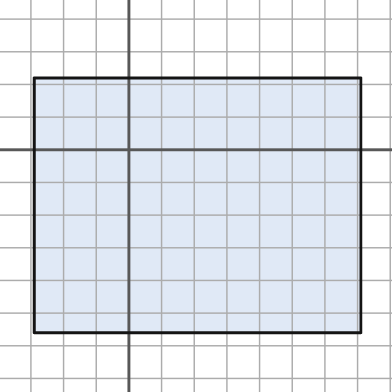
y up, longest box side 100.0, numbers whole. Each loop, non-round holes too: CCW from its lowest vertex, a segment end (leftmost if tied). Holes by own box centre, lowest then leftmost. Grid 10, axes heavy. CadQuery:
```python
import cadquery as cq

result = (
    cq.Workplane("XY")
    .moveTo(-29.0, -56.0)
    .lineTo(71.0, -56.0)
    .lineTo(71.0, 22.0)
    .lineTo(-29.0, 22.0)
    .close()
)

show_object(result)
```